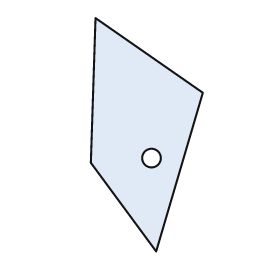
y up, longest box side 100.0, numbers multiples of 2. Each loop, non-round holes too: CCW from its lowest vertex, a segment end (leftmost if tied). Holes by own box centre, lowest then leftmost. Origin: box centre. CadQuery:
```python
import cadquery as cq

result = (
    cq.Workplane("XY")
    .moveTo(4.0, -50.0)
    .lineTo(24.0, 18.0)
    .lineTo(-22.0, 50.0)
    .lineTo(-24.0, -12.0)
    .close()
    .moveTo(2.0, -10.0)
    .circle(4.0)
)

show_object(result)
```